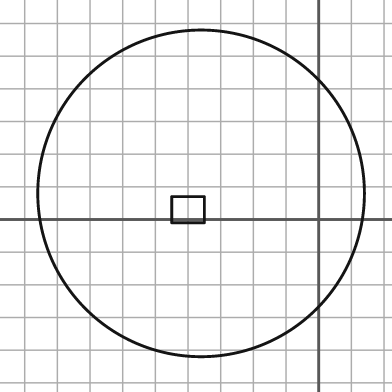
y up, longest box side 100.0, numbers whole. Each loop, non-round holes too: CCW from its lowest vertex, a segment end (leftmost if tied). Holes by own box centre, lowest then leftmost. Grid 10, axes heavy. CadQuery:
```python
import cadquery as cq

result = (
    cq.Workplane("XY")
    .moveTo(-36.0, 8.0)
    .circle(50.0)
    .moveTo(-45.0, -1.0)
    .lineTo(-35.0, -1.0)
    .lineTo(-35.0, 7.0)
    .lineTo(-45.0, 7.0)
    .close()
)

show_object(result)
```